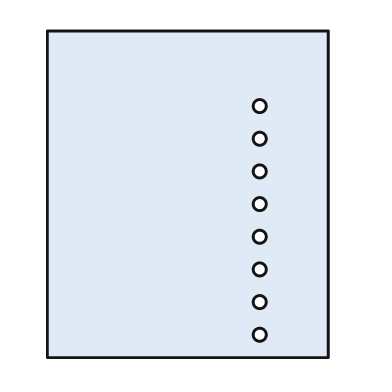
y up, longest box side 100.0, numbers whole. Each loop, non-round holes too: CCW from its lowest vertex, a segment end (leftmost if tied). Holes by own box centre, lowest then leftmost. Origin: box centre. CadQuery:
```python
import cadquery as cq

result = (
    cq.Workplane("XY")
    .moveTo(-43.0, -50.0)
    .lineTo(43.0, -50.0)
    .lineTo(43.0, 50.0)
    .lineTo(-43.0, 50.0)
    .close()
    .moveTo(22.0, -43.0)
    .circle(2.0)
    .moveTo(22.0, -33.0)
    .circle(2.0)
    .moveTo(22.0, -23.0)
    .circle(2.0)
    .moveTo(22.0, -13.0)
    .circle(2.0)
    .moveTo(22.0, -3.0)
    .circle(2.0)
    .moveTo(22.0, 7.0)
    .circle(2.0)
    .moveTo(22.0, 17.0)
    .circle(2.0)
    .moveTo(22.0, 27.0)
    .circle(2.0)
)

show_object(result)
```